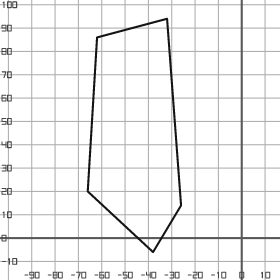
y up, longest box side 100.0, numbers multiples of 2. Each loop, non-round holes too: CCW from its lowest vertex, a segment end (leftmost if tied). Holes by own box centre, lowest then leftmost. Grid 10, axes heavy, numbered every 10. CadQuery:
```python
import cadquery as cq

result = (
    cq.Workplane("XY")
    .moveTo(-38.0, -6.0)
    .lineTo(-26.0, 14.0)
    .lineTo(-32.0, 94.0)
    .lineTo(-62.0, 86.0)
    .lineTo(-66.0, 20.0)
    .close()
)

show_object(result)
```